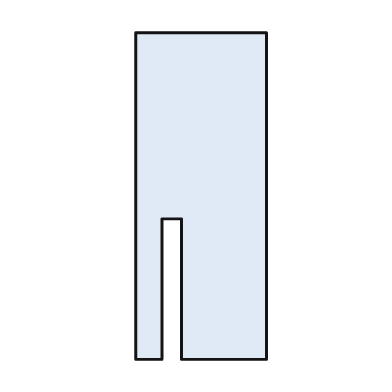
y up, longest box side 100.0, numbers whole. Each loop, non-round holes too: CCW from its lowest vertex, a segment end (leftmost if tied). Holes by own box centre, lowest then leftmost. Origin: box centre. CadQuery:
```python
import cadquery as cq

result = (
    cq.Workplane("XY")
    .moveTo(-20.0, -50.0)
    .lineTo(-12.0, -50.0)
    .lineTo(-12.0, -7.0)
    .lineTo(-6.0, -7.0)
    .lineTo(-6.0, -50.0)
    .lineTo(20.0, -50.0)
    .lineTo(20.0, 50.0)
    .lineTo(-20.0, 50.0)
    .close()
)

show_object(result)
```